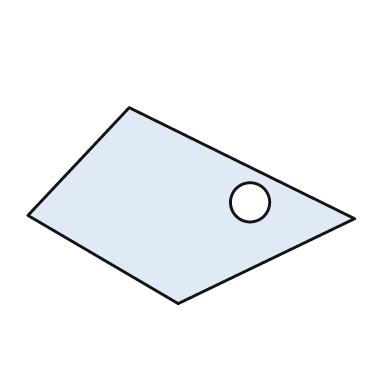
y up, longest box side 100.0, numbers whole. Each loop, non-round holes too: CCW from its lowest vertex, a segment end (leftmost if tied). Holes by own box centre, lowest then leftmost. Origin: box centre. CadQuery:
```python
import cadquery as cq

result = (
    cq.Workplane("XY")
    .moveTo(-4.0, -30.0)
    .lineTo(50.0, -4.0)
    .lineTo(-19.0, 30.0)
    .lineTo(-50.0, -3.0)
    .close()
    .moveTo(18.0, 1.0)
    .circle(6.0)
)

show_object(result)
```